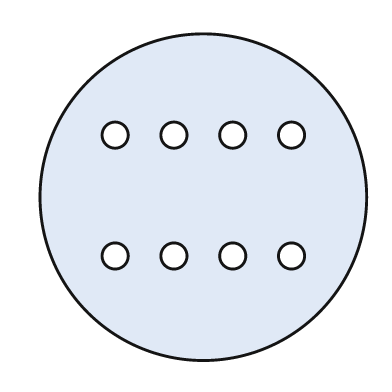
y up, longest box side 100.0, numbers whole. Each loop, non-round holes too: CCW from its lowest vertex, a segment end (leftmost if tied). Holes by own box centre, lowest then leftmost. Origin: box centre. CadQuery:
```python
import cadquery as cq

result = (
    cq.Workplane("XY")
    .moveTo(0.0, 0.0)
    .circle(50.0)
    .moveTo(-27.0, -18.0)
    .circle(4.0)
    .moveTo(-9.0, -18.0)
    .circle(4.0)
    .moveTo(9.0, -18.0)
    .circle(4.0)
    .moveTo(27.0, -18.0)
    .circle(4.0)
    .moveTo(-27.0, 19.0)
    .circle(4.0)
    .moveTo(-9.0, 19.0)
    .circle(4.0)
    .moveTo(9.0, 19.0)
    .circle(4.0)
    .moveTo(27.0, 19.0)
    .circle(4.0)
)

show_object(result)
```